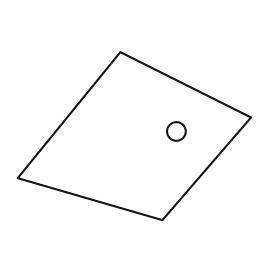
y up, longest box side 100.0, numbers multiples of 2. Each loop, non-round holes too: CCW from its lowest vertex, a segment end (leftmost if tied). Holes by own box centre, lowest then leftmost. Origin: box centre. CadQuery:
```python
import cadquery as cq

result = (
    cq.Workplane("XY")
    .moveTo(12.0, -36.0)
    .lineTo(50.0, 8.0)
    .lineTo(-6.0, 36.0)
    .lineTo(-50.0, -18.0)
    .close()
    .moveTo(18.0, 2.0)
    .circle(4.0)
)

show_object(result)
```